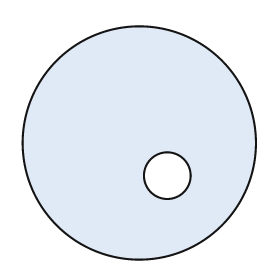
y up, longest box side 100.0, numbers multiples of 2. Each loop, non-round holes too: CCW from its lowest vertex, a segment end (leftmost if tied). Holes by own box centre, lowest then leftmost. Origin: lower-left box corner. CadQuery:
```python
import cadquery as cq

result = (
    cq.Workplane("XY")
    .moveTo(50.0, 50.0)
    .circle(50.0)
    .moveTo(62.0, 36.0)
    .circle(10.0)
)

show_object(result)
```